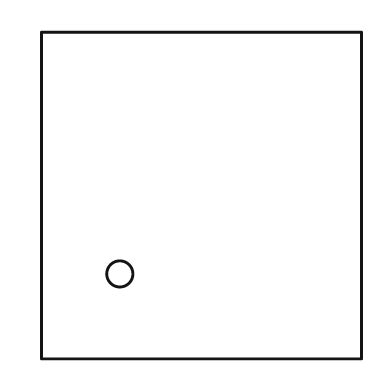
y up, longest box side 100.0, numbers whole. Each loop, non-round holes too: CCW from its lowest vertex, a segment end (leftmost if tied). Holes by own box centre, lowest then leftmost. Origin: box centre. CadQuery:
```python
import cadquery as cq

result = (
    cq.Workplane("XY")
    .moveTo(-49.0, -50.0)
    .lineTo(49.0, -50.0)
    .lineTo(49.0, 50.0)
    .lineTo(-49.0, 50.0)
    .close()
    .moveTo(-25.0, -24.0)
    .circle(4.0)
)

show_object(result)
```